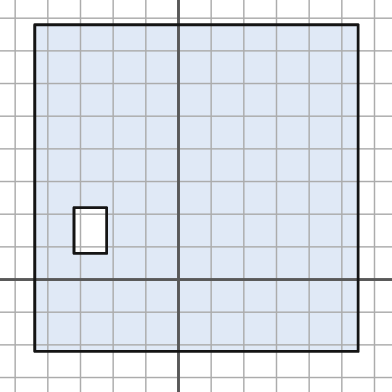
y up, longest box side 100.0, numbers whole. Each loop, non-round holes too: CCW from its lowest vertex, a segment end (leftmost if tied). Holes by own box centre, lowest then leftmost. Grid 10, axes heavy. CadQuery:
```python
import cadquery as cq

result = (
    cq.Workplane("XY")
    .moveTo(-44.0, -22.0)
    .lineTo(55.0, -22.0)
    .lineTo(55.0, 78.0)
    .lineTo(-44.0, 78.0)
    .close()
    .moveTo(-32.0, 8.0)
    .lineTo(-22.0, 8.0)
    .lineTo(-22.0, 22.0)
    .lineTo(-32.0, 22.0)
    .close()
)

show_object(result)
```